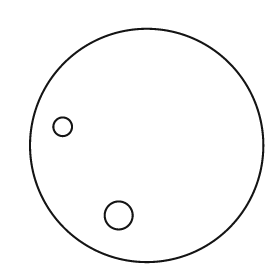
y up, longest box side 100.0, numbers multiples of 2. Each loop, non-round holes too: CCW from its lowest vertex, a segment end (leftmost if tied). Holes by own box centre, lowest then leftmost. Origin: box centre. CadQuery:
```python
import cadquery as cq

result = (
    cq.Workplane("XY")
    .moveTo(0.0, 0.0)
    .circle(50.0)
    .moveTo(-12.0, -30.0)
    .circle(6.0)
    .moveTo(-36.0, 8.0)
    .circle(4.0)
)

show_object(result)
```